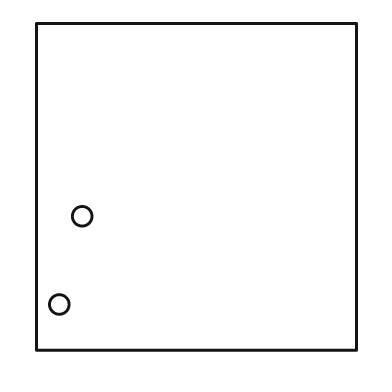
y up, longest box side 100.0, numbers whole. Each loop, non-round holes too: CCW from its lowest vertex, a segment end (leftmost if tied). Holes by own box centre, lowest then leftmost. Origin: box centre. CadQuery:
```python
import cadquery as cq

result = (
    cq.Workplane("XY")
    .moveTo(-49.0, -50.0)
    .lineTo(49.0, -50.0)
    .lineTo(49.0, 50.0)
    .lineTo(-49.0, 50.0)
    .close()
    .moveTo(-42.0, -36.0)
    .circle(3.0)
    .moveTo(-35.0, -9.0)
    .circle(3.0)
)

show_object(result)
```